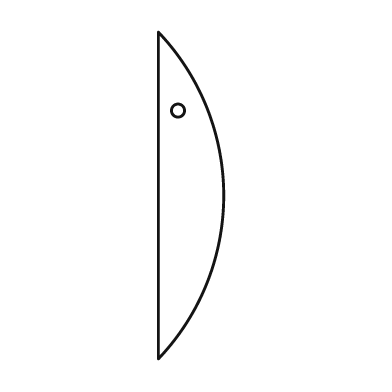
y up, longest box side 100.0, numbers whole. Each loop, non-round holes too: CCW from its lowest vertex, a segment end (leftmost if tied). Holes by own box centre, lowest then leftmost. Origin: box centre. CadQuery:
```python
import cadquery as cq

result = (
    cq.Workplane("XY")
    .moveTo(-10.0, -50.0)
    .threePointArc((10.0, 0.0), (-10.0, 50.0))
    .close()
    .moveTo(-4.0, 26.0)
    .circle(2.0)
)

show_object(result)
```